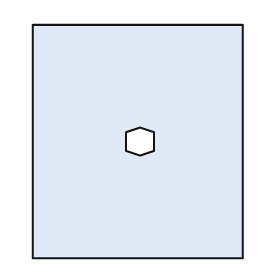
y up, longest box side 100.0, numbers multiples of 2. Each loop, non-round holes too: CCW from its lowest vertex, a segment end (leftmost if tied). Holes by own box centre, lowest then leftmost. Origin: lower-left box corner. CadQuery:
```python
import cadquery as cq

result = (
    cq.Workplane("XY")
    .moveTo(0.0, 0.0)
    .lineTo(90.0, 0.0)
    .lineTo(90.0, 100.0)
    .lineTo(0.0, 100.0)
    .close()
    .moveTo(46.0, 44.0)
    .lineTo(52.0, 46.0)
    .lineTo(52.0, 54.0)
    .lineTo(46.0, 56.0)
    .lineTo(40.0, 54.0)
    .lineTo(40.0, 46.0)
    .close()
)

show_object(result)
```